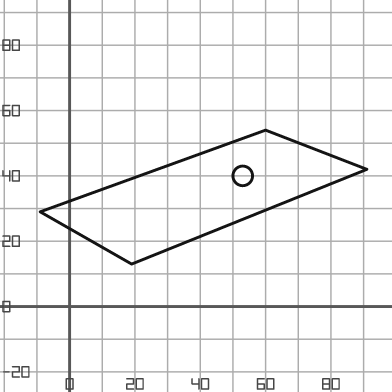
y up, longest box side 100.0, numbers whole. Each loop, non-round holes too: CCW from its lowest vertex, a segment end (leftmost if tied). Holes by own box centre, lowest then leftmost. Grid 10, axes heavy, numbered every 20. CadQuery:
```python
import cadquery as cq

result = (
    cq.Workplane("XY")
    .moveTo(19.0, 13.0)
    .lineTo(91.0, 42.0)
    .lineTo(60.0, 54.0)
    .lineTo(-9.0, 29.0)
    .close()
    .moveTo(53.0, 40.0)
    .circle(3.0)
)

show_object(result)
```